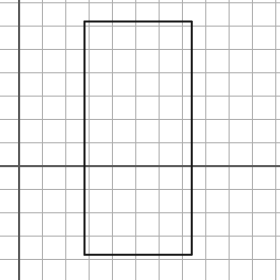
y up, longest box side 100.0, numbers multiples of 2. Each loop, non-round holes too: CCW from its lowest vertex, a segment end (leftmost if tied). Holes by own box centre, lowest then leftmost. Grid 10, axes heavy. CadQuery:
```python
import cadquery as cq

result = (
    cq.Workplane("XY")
    .moveTo(28.0, -38.0)
    .lineTo(74.0, -38.0)
    .lineTo(74.0, 62.0)
    .lineTo(28.0, 62.0)
    .close()
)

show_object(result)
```